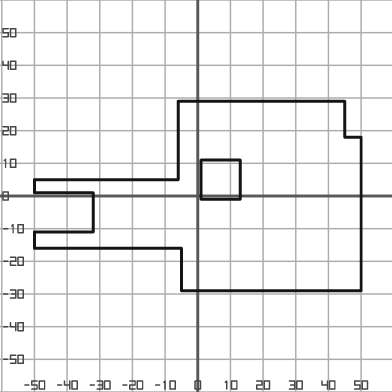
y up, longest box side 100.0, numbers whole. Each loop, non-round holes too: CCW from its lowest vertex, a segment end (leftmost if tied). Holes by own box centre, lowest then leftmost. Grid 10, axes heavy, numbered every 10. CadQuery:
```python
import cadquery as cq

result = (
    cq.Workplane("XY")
    .moveTo(-5.0, -29.0)
    .lineTo(50.0, -29.0)
    .lineTo(50.0, 18.0)
    .lineTo(45.0, 18.0)
    .lineTo(45.0, 29.0)
    .lineTo(-6.0, 29.0)
    .lineTo(-6.0, 5.0)
    .lineTo(-50.0, 5.0)
    .lineTo(-50.0, 1.0)
    .lineTo(-32.0, 1.0)
    .lineTo(-32.0, -11.0)
    .lineTo(-50.0, -11.0)
    .lineTo(-50.0, -16.0)
    .lineTo(-5.0, -16.0)
    .close()
    .moveTo(1.0, -1.0)
    .lineTo(13.0, -1.0)
    .lineTo(13.0, 11.0)
    .lineTo(1.0, 11.0)
    .close()
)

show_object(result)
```